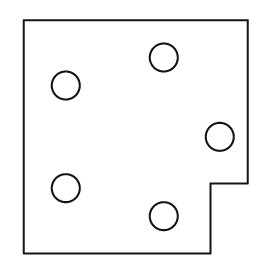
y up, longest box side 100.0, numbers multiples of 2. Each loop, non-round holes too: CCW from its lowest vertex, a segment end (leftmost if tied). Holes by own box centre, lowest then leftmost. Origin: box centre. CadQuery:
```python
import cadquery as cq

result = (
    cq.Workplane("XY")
    .moveTo(-48.0, -50.0)
    .lineTo(32.0, -50.0)
    .lineTo(32.0, -20.0)
    .lineTo(48.0, -20.0)
    .lineTo(48.0, 50.0)
    .lineTo(-48.0, 50.0)
    .close()
    .moveTo(12.0, -34.0)
    .circle(6.0)
    .moveTo(-30.0, -22.0)
    .circle(6.0)
    .moveTo(36.0, 0.0)
    .circle(6.0)
    .moveTo(-30.0, 22.0)
    .circle(6.0)
    .moveTo(12.0, 34.0)
    .circle(6.0)
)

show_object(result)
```